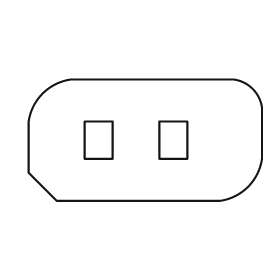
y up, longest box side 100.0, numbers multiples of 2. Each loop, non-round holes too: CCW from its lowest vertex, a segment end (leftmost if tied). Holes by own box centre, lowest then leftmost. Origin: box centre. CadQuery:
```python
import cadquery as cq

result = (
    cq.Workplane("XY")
    .moveTo(-38.0, -26.0)
    .lineTo(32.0, -26.0)
    .threePointArc((44.0, -20.0), (50.0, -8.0))
    .lineTo(50.0, 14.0)
    .threePointArc((46.0, 22.0), (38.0, 26.0))
    .lineTo(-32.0, 26.0)
    .threePointArc((-44.0, 20.0), (-50.0, 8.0))
    .lineTo(-50.0, -14.0)
    .close()
    .moveTo(-26.0, -8.0)
    .lineTo(-14.0, -8.0)
    .lineTo(-14.0, 8.0)
    .lineTo(-26.0, 8.0)
    .close()
    .moveTo(6.0, -8.0)
    .lineTo(18.0, -8.0)
    .lineTo(18.0, 8.0)
    .lineTo(6.0, 8.0)
    .close()
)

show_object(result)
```